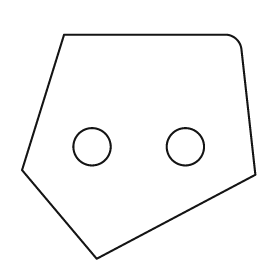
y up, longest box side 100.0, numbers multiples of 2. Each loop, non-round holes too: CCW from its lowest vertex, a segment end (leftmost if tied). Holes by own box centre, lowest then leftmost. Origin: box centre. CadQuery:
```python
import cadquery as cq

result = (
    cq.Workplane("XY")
    .moveTo(-18.0, -48.0)
    .lineTo(50.0, -12.0)
    .lineTo(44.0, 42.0)
    .threePointArc((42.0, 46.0), (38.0, 48.0))
    .lineTo(-32.0, 48.0)
    .lineTo(-50.0, -10.0)
    .close()
    .moveTo(-20.0, 0.0)
    .circle(8.0)
    .moveTo(20.0, 0.0)
    .circle(8.0)
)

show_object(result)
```